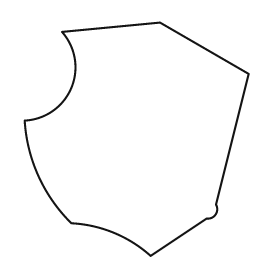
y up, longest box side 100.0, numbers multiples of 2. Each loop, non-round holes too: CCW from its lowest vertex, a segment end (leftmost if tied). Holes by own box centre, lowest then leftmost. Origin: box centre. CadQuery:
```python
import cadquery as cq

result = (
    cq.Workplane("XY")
    .moveTo(6.0, -50.0)
    .lineTo(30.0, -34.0)
    .threePointArc((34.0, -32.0), (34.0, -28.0))
    .lineTo(48.0, 28.0)
    .lineTo(10.0, 50.0)
    .lineTo(-32.0, 46.0)
    .threePointArc((-28.0, 22.0), (-48.0, 8.0))
    .threePointArc((-42.0, -16.0), (-28.0, -36.0))
    .threePointArc((-10.0, -40.0), (6.0, -50.0))
    .close()
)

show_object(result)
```